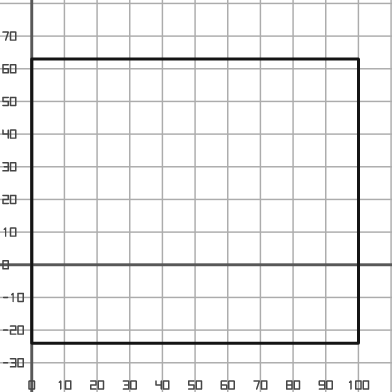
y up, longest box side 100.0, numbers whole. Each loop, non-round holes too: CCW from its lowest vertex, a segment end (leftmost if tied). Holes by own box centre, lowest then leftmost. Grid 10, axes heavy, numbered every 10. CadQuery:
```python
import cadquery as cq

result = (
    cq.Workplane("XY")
    .moveTo(0.0, -24.0)
    .lineTo(100.0, -24.0)
    .lineTo(100.0, 63.0)
    .lineTo(0.0, 63.0)
    .close()
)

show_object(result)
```